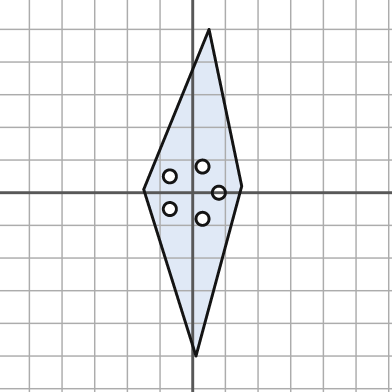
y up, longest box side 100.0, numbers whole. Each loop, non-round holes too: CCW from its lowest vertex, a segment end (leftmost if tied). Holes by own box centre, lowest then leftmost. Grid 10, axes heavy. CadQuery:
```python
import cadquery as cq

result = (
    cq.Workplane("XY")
    .moveTo(1.0, -50.0)
    .lineTo(15.0, 2.0)
    .lineTo(5.0, 50.0)
    .lineTo(-15.0, 1.0)
    .close()
    .moveTo(3.0, -8.0)
    .circle(2.0)
    .moveTo(-7.0, -5.0)
    .circle(2.0)
    .moveTo(8.0, 0.0)
    .circle(2.0)
    .moveTo(-7.0, 5.0)
    .circle(2.0)
    .moveTo(3.0, 8.0)
    .circle(2.0)
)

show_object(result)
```